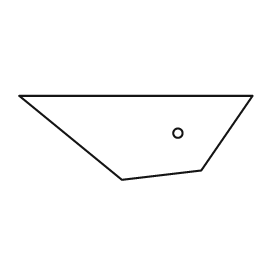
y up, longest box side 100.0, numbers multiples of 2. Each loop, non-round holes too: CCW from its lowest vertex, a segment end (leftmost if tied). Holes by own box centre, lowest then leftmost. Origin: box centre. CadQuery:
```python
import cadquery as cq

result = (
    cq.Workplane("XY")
    .moveTo(-6.0, -18.0)
    .lineTo(28.0, -14.0)
    .lineTo(50.0, 18.0)
    .lineTo(-50.0, 18.0)
    .close()
    .moveTo(18.0, 2.0)
    .circle(2.0)
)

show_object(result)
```